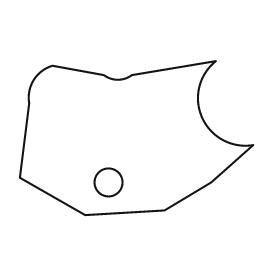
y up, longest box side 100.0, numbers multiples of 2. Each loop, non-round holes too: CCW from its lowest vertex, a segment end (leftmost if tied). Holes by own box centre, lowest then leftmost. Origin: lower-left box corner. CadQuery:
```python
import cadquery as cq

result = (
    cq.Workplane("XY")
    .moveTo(28.0, 0.0)
    .lineTo(62.0, 2.0)
    .lineTo(82.0, 14.0)
    .lineTo(100.0, 30.0)
    .threePointArc((78.0, 42.0), (84.0, 66.0))
    .lineTo(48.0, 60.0)
    .threePointArc((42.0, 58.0), (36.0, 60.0))
    .lineTo(14.0, 64.0)
    .threePointArc((6.0, 58.0), (4.0, 48.0))
    .lineTo(0.0, 16.0)
    .close()
    .moveTo(38.0, 14.0)
    .circle(6.0)
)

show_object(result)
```